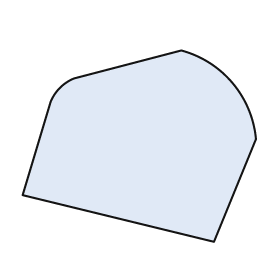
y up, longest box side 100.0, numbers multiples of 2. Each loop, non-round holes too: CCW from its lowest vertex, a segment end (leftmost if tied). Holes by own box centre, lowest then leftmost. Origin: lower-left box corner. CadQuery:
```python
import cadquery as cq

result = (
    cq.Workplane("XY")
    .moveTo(82.0, 0.0)
    .lineTo(100.0, 44.0)
    .threePointArc((90.0, 68.0), (68.0, 82.0))
    .lineTo(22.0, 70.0)
    .threePointArc((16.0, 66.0), (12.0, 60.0))
    .lineTo(0.0, 20.0)
    .close()
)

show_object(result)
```